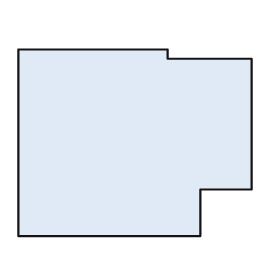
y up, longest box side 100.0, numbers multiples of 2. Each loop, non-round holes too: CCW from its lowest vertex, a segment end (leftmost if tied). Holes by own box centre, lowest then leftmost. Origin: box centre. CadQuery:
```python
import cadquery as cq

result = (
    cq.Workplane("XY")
    .moveTo(-50.0, -40.0)
    .lineTo(28.0, -40.0)
    .lineTo(28.0, -20.0)
    .lineTo(50.0, -20.0)
    .lineTo(50.0, 36.0)
    .lineTo(14.0, 36.0)
    .lineTo(14.0, 40.0)
    .lineTo(-50.0, 40.0)
    .close()
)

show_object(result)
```